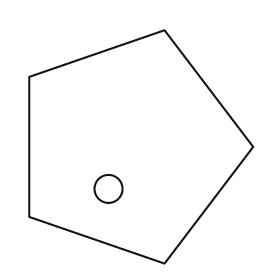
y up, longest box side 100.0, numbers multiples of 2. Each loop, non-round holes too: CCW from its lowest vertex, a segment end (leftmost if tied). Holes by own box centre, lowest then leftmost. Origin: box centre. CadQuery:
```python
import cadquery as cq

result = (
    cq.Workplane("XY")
    .moveTo(10.0, -50.0)
    .lineTo(48.0, 0.0)
    .lineTo(10.0, 50.0)
    .lineTo(-48.0, 30.0)
    .lineTo(-48.0, -30.0)
    .close()
    .moveTo(-14.0, -18.0)
    .circle(6.0)
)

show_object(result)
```